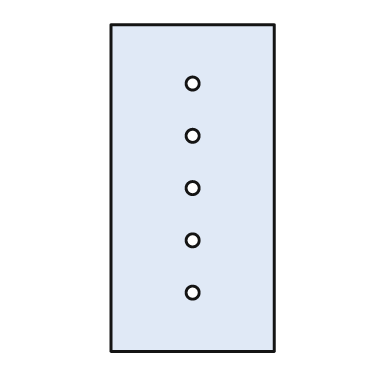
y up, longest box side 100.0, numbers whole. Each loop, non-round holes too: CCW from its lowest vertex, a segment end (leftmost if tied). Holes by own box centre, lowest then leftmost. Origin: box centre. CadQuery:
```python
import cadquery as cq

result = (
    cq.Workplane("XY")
    .moveTo(-25.0, -50.0)
    .lineTo(25.0, -50.0)
    .lineTo(25.0, 50.0)
    .lineTo(-25.0, 50.0)
    .close()
    .moveTo(0.0, -32.0)
    .circle(2.0)
    .moveTo(0.0, -16.0)
    .circle(2.0)
    .moveTo(0.0, 0.0)
    .circle(2.0)
    .moveTo(0.0, 16.0)
    .circle(2.0)
    .moveTo(0.0, 32.0)
    .circle(2.0)
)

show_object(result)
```